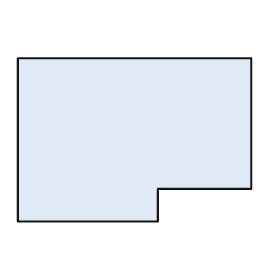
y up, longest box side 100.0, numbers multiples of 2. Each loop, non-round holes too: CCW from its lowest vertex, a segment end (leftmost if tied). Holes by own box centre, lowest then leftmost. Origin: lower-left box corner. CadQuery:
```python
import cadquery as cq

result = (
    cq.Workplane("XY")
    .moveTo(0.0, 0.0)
    .lineTo(60.0, 0.0)
    .lineTo(60.0, 14.0)
    .lineTo(100.0, 14.0)
    .lineTo(100.0, 70.0)
    .lineTo(0.0, 70.0)
    .close()
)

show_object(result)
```